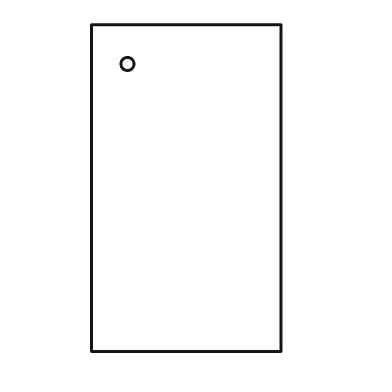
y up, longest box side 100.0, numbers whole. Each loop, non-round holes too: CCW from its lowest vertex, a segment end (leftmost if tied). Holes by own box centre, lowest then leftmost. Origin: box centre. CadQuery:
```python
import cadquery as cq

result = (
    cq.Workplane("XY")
    .moveTo(-29.0, -50.0)
    .lineTo(29.0, -50.0)
    .lineTo(29.0, 50.0)
    .lineTo(-29.0, 50.0)
    .close()
    .moveTo(-18.0, 38.0)
    .circle(2.0)
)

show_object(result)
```